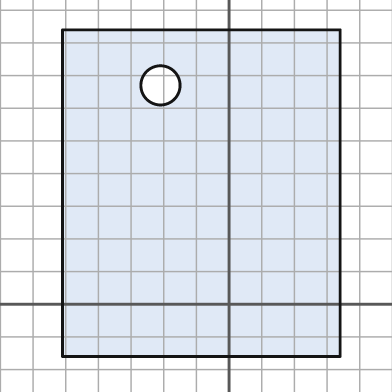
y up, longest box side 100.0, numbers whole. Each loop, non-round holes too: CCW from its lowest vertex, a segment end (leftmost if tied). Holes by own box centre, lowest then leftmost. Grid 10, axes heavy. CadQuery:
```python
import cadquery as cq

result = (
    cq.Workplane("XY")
    .moveTo(-51.0, -16.0)
    .lineTo(34.0, -16.0)
    .lineTo(34.0, 84.0)
    .lineTo(-51.0, 84.0)
    .close()
    .moveTo(-21.0, 67.0)
    .circle(6.0)
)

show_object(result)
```